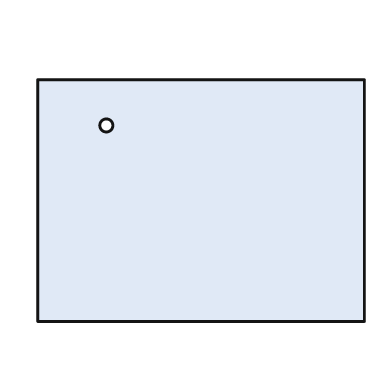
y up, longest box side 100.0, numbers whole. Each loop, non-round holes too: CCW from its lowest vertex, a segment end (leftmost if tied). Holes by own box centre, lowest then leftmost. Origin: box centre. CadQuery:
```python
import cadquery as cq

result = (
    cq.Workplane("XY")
    .moveTo(-50.0, -37.0)
    .lineTo(50.0, -37.0)
    .lineTo(50.0, 37.0)
    .lineTo(-50.0, 37.0)
    .close()
    .moveTo(-29.0, 23.0)
    .circle(2.0)
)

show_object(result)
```